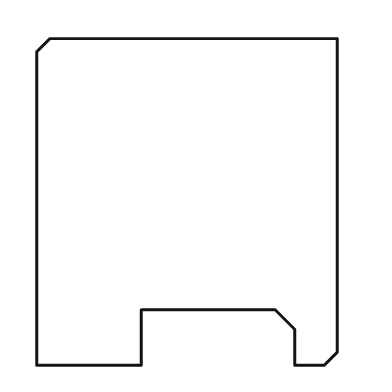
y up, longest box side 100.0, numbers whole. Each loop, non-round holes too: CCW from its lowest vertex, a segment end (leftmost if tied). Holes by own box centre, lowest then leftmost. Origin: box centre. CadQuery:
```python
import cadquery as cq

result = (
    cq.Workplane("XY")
    .moveTo(-46.0, -50.0)
    .lineTo(-14.0, -50.0)
    .lineTo(-14.0, -33.0)
    .lineTo(27.0, -33.0)
    .lineTo(33.0, -39.0)
    .lineTo(33.0, -50.0)
    .lineTo(42.0, -50.0)
    .lineTo(46.0, -46.0)
    .lineTo(46.0, 50.0)
    .lineTo(-42.0, 50.0)
    .lineTo(-46.0, 46.0)
    .close()
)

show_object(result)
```